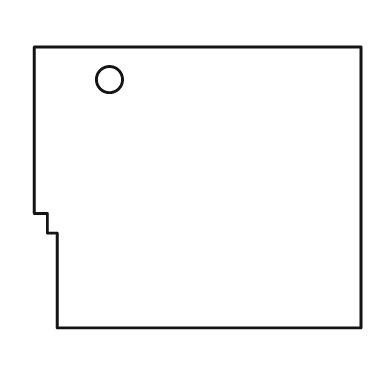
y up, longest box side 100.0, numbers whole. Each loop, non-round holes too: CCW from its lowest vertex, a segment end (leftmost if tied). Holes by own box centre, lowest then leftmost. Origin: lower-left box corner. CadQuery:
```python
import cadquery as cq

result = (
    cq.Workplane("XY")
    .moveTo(7.0, 0.0)
    .lineTo(100.0, 0.0)
    .lineTo(100.0, 86.0)
    .lineTo(0.0, 86.0)
    .lineTo(0.0, 35.0)
    .lineTo(4.0, 35.0)
    .lineTo(4.0, 29.0)
    .lineTo(7.0, 29.0)
    .close()
    .moveTo(23.0, 76.0)
    .circle(4.0)
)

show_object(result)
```